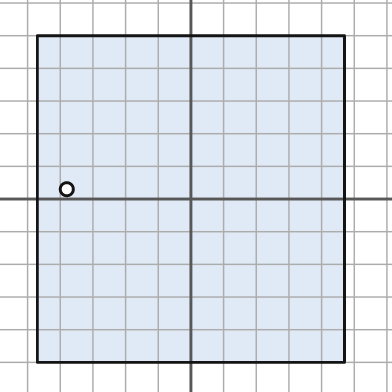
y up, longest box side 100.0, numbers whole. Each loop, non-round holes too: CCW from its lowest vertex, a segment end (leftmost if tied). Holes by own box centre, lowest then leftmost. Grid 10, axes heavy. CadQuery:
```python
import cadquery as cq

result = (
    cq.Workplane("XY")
    .moveTo(-47.0, -50.0)
    .lineTo(47.0, -50.0)
    .lineTo(47.0, 50.0)
    .lineTo(-47.0, 50.0)
    .close()
    .moveTo(-38.0, 3.0)
    .circle(2.0)
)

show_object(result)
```